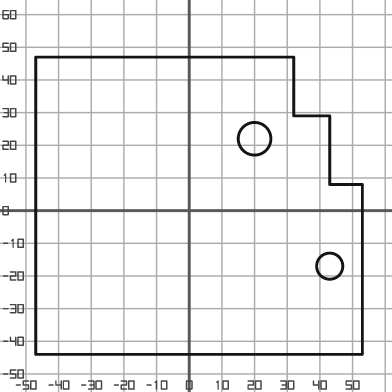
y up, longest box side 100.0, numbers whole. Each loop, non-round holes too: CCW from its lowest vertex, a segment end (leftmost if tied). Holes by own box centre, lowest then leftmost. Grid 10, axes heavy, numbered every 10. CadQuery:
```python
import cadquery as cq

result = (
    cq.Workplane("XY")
    .moveTo(-47.0, -44.0)
    .lineTo(53.0, -44.0)
    .lineTo(53.0, 8.0)
    .lineTo(43.0, 8.0)
    .lineTo(43.0, 29.0)
    .lineTo(32.0, 29.0)
    .lineTo(32.0, 47.0)
    .lineTo(-47.0, 47.0)
    .close()
    .moveTo(43.0, -17.0)
    .circle(4.0)
    .moveTo(20.0, 22.0)
    .circle(5.0)
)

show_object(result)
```